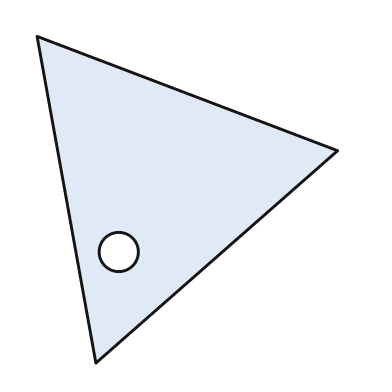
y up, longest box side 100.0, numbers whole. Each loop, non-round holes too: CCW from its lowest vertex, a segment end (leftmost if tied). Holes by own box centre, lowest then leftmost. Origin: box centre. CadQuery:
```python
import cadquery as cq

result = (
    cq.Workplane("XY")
    .moveTo(-28.0, -50.0)
    .lineTo(46.0, 15.0)
    .lineTo(-46.0, 50.0)
    .close()
    .moveTo(-21.0, -16.0)
    .circle(6.0)
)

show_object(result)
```